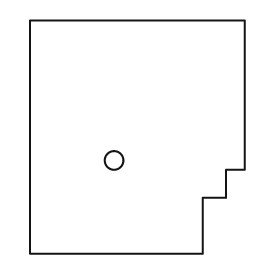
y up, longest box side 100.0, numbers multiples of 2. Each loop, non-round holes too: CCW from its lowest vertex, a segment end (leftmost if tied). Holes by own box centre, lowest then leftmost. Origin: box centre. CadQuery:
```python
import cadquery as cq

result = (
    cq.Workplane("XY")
    .moveTo(-46.0, -50.0)
    .lineTo(28.0, -50.0)
    .lineTo(28.0, -26.0)
    .lineTo(38.0, -26.0)
    .lineTo(38.0, -14.0)
    .lineTo(46.0, -14.0)
    .lineTo(46.0, 50.0)
    .lineTo(-46.0, 50.0)
    .close()
    .moveTo(-10.0, -10.0)
    .circle(4.0)
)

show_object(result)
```